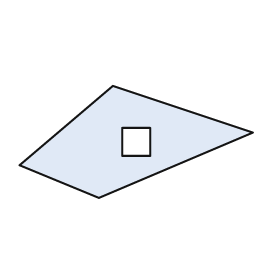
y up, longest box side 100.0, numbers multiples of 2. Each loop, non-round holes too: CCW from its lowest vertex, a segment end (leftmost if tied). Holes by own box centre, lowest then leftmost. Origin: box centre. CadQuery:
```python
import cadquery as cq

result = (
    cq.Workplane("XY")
    .moveTo(-16.0, -24.0)
    .lineTo(50.0, 4.0)
    .lineTo(-10.0, 24.0)
    .lineTo(-50.0, -10.0)
    .close()
    .moveTo(-6.0, -6.0)
    .lineTo(6.0, -6.0)
    .lineTo(6.0, 6.0)
    .lineTo(-6.0, 6.0)
    .close()
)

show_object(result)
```